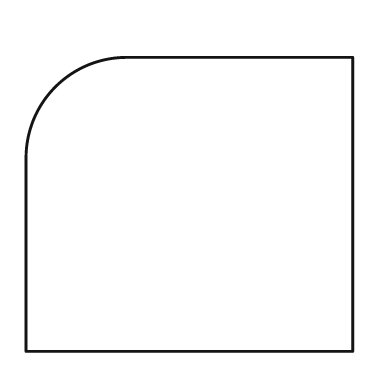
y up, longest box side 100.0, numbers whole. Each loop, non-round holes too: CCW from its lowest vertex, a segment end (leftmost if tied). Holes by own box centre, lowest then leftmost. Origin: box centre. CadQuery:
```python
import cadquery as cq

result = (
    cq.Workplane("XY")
    .moveTo(-50.0, -45.0)
    .lineTo(50.0, -45.0)
    .lineTo(50.0, 45.0)
    .lineTo(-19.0, 45.0)
    .threePointArc((-41.0, 36.0), (-50.0, 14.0))
    .close()
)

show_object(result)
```